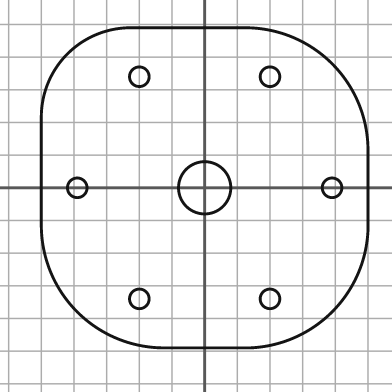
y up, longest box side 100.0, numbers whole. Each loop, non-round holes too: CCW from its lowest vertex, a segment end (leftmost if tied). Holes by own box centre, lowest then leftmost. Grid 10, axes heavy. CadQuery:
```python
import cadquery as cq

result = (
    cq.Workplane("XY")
    .moveTo(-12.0, -49.0)
    .lineTo(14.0, -49.0)
    .threePointArc((39.0, -38.0), (50.0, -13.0))
    .lineTo(50.0, 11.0)
    .threePointArc((39.0, 38.0), (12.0, 49.0))
    .lineTo(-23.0, 49.0)
    .threePointArc((-42.0, 41.0), (-50.0, 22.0))
    .lineTo(-50.0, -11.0)
    .threePointArc((-39.0, -38.0), (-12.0, -49.0))
    .close()
    .moveTo(-20.0, -34.0)
    .circle(3.0)
    .moveTo(20.0, -34.0)
    .circle(3.0)
    .moveTo(-39.0, 0.0)
    .circle(3.0)
    .moveTo(0.0, 0.0)
    .circle(8.0)
    .moveTo(39.0, 0.0)
    .circle(3.0)
    .moveTo(-20.0, 34.0)
    .circle(3.0)
    .moveTo(20.0, 34.0)
    .circle(3.0)
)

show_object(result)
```